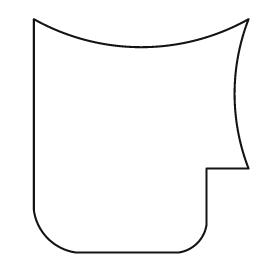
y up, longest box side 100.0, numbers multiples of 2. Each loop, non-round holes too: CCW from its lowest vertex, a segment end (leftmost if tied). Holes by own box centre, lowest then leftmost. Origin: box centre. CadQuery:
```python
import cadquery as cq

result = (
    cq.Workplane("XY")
    .moveTo(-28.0, -50.0)
    .lineTo(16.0, -50.0)
    .threePointArc((24.0, -46.0), (28.0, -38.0))
    .lineTo(28.0, -14.0)
    .lineTo(46.0, -14.0)
    .threePointArc((40.0, 18.0), (46.0, 50.0))
    .threePointArc((0.0, 38.0), (-46.0, 50.0))
    .lineTo(-46.0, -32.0)
    .threePointArc((-40.0, -44.0), (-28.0, -50.0))
    .close()
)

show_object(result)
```